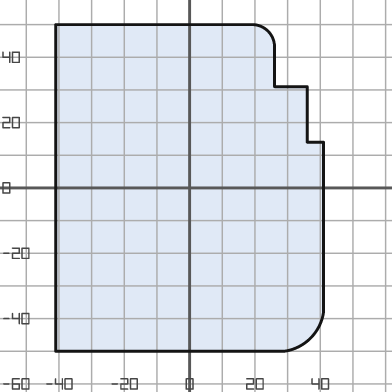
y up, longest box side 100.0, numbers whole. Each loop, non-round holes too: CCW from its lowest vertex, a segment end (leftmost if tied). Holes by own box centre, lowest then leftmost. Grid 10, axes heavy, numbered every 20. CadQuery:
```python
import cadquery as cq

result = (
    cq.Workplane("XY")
    .moveTo(-41.0, -50.0)
    .lineTo(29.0, -50.0)
    .threePointArc((37.0, -46.0), (41.0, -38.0))
    .lineTo(41.0, 14.0)
    .lineTo(36.0, 14.0)
    .lineTo(36.0, 31.0)
    .lineTo(26.0, 31.0)
    .lineTo(26.0, 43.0)
    .threePointArc((24.0, 48.0), (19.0, 50.0))
    .lineTo(-41.0, 50.0)
    .close()
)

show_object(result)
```